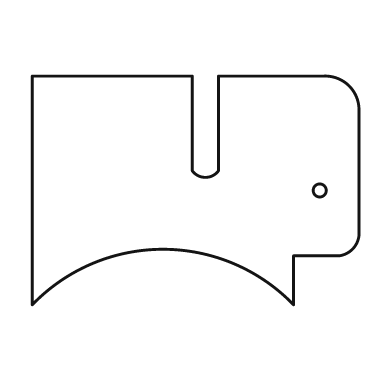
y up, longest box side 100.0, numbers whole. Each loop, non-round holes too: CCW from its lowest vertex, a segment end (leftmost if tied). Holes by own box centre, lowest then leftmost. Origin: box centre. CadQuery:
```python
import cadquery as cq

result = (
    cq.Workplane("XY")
    .moveTo(-50.0, -35.0)
    .threePointArc((-10.0, -18.0), (30.0, -35.0))
    .lineTo(30.0, -20.0)
    .lineTo(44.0, -20.0)
    .threePointArc((48.0, -18.0), (50.0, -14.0))
    .lineTo(50.0, 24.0)
    .threePointArc((47.0, 32.0), (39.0, 35.0))
    .lineTo(7.0, 35.0)
    .lineTo(7.0, 6.0)
    .threePointArc((3.0, 4.0), (-1.0, 6.0))
    .lineTo(-1.0, 35.0)
    .lineTo(-50.0, 35.0)
    .close()
    .moveTo(38.0, 0.0)
    .circle(2.0)
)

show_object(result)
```